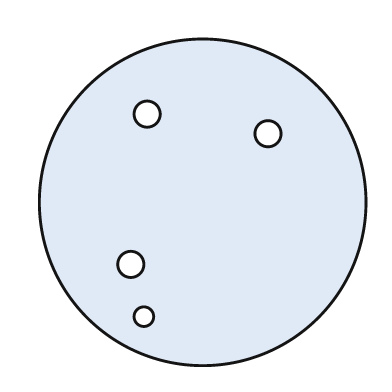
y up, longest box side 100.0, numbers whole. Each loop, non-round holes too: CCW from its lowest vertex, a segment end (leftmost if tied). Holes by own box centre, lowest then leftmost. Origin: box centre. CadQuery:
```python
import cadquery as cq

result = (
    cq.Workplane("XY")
    .moveTo(0.0, 0.0)
    .circle(50.0)
    .moveTo(-18.0, -35.0)
    .circle(3.0)
    .moveTo(-22.0, -19.0)
    .circle(4.0)
    .moveTo(20.0, 21.0)
    .circle(4.0)
    .moveTo(-17.0, 27.0)
    .circle(4.0)
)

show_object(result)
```